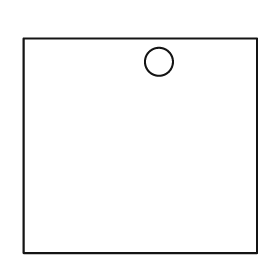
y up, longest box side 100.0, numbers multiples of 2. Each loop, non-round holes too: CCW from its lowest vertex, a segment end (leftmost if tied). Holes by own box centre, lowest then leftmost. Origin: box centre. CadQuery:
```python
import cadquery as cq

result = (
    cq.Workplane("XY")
    .moveTo(-50.0, -46.0)
    .lineTo(50.0, -46.0)
    .lineTo(50.0, 46.0)
    .lineTo(-50.0, 46.0)
    .close()
    .moveTo(8.0, 36.0)
    .circle(6.0)
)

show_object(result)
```